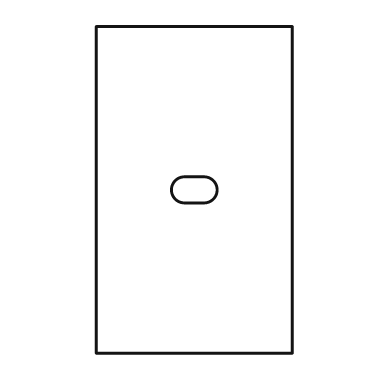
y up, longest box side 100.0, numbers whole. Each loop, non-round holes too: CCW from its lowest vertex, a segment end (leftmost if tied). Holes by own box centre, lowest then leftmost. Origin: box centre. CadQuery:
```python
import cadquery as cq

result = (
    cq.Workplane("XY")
    .moveTo(-30.0, -50.0)
    .lineTo(30.0, -50.0)
    .lineTo(30.0, 50.0)
    .lineTo(-30.0, 50.0)
    .close()
    .moveTo(-3.0, -4.0)
    .lineTo(3.0, -4.0)
    .threePointArc((7.0, 0.0), (3.0, 4.0))
    .lineTo(-3.0, 4.0)
    .threePointArc((-7.0, 0.0), (-3.0, -4.0))
    .close()
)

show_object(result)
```